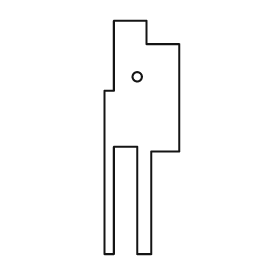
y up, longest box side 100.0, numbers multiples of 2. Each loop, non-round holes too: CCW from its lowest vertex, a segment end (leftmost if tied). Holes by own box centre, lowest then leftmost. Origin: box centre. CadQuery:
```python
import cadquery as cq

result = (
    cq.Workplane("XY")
    .moveTo(-16.0, -50.0)
    .lineTo(-12.0, -50.0)
    .lineTo(-12.0, -4.0)
    .lineTo(-2.0, -4.0)
    .lineTo(-2.0, -50.0)
    .lineTo(4.0, -50.0)
    .lineTo(4.0, -6.0)
    .lineTo(16.0, -6.0)
    .lineTo(16.0, 40.0)
    .lineTo(2.0, 40.0)
    .lineTo(2.0, 50.0)
    .lineTo(-12.0, 50.0)
    .lineTo(-12.0, 20.0)
    .lineTo(-16.0, 20.0)
    .close()
    .moveTo(-2.0, 26.0)
    .circle(2.0)
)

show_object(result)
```